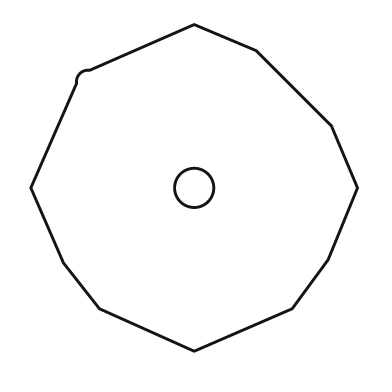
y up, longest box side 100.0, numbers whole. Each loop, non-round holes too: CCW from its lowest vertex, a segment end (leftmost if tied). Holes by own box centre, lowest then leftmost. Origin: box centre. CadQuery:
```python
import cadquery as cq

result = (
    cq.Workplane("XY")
    .moveTo(0.0, -50.0)
    .lineTo(30.0, -37.0)
    .lineTo(41.0, -22.0)
    .lineTo(50.0, 0.0)
    .lineTo(42.0, 19.0)
    .lineTo(19.0, 42.0)
    .lineTo(0.0, 50.0)
    .lineTo(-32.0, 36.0)
    .threePointArc((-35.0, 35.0), (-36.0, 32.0))
    .lineTo(-50.0, 0.0)
    .lineTo(-40.0, -23.0)
    .lineTo(-29.0, -37.0)
    .close()
    .moveTo(0.0, 0.0)
    .circle(6.0)
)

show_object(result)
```